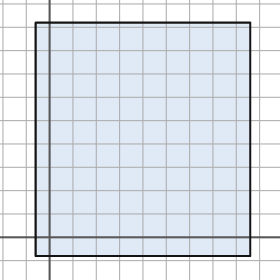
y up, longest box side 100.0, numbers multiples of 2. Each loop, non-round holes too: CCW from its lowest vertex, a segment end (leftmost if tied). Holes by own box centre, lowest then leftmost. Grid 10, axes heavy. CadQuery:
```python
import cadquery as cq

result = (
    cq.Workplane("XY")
    .moveTo(-6.0, -8.0)
    .lineTo(86.0, -8.0)
    .lineTo(86.0, 92.0)
    .lineTo(-6.0, 92.0)
    .close()
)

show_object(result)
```